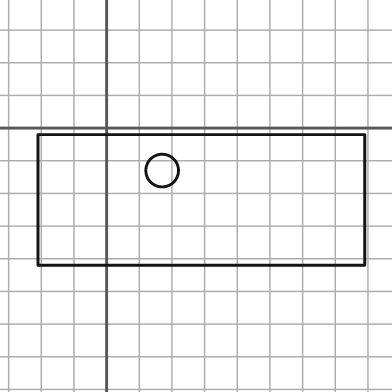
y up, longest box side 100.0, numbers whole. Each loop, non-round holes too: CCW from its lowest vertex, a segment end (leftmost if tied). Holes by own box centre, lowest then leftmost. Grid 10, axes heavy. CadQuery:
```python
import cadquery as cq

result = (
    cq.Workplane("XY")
    .moveTo(-21.0, -42.0)
    .lineTo(79.0, -42.0)
    .lineTo(79.0, -2.0)
    .lineTo(-21.0, -2.0)
    .close()
    .moveTo(17.0, -13.0)
    .circle(5.0)
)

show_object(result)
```